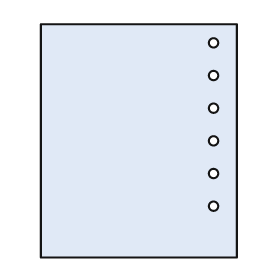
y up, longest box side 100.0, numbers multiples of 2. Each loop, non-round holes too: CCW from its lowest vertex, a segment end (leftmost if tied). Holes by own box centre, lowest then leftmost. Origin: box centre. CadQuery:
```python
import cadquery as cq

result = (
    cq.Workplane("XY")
    .moveTo(-42.0, -50.0)
    .lineTo(42.0, -50.0)
    .lineTo(42.0, 50.0)
    .lineTo(-42.0, 50.0)
    .close()
    .moveTo(32.0, -28.0)
    .circle(2.0)
    .moveTo(32.0, -14.0)
    .circle(2.0)
    .moveTo(32.0, 0.0)
    .circle(2.0)
    .moveTo(32.0, 14.0)
    .circle(2.0)
    .moveTo(32.0, 28.0)
    .circle(2.0)
    .moveTo(32.0, 42.0)
    .circle(2.0)
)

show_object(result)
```